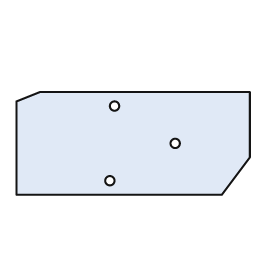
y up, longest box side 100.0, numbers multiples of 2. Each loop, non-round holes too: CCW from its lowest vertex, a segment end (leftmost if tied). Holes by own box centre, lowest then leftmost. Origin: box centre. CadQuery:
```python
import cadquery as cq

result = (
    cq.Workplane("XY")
    .moveTo(-50.0, -22.0)
    .lineTo(38.0, -22.0)
    .lineTo(50.0, -6.0)
    .lineTo(50.0, 22.0)
    .lineTo(-40.0, 22.0)
    .lineTo(-50.0, 18.0)
    .close()
    .moveTo(-10.0, -16.0)
    .circle(2.0)
    .moveTo(18.0, 0.0)
    .circle(2.0)
    .moveTo(-8.0, 16.0)
    .circle(2.0)
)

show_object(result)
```